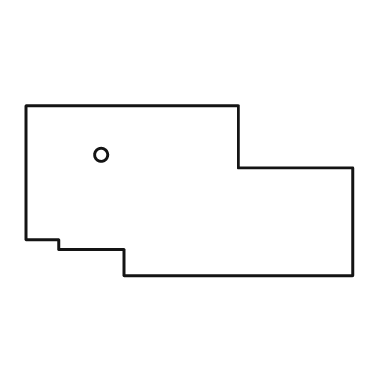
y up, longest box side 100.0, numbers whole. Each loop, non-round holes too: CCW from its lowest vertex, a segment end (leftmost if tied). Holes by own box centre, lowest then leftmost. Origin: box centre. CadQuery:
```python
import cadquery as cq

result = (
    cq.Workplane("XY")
    .moveTo(-20.0, -26.0)
    .lineTo(50.0, -26.0)
    .lineTo(50.0, 7.0)
    .lineTo(15.0, 7.0)
    .lineTo(15.0, 26.0)
    .lineTo(-50.0, 26.0)
    .lineTo(-50.0, -15.0)
    .lineTo(-40.0, -15.0)
    .lineTo(-40.0, -18.0)
    .lineTo(-20.0, -18.0)
    .close()
    .moveTo(-27.0, 11.0)
    .circle(2.0)
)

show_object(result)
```